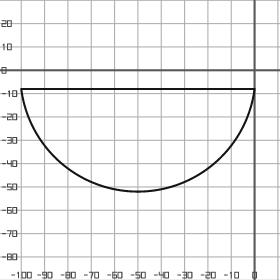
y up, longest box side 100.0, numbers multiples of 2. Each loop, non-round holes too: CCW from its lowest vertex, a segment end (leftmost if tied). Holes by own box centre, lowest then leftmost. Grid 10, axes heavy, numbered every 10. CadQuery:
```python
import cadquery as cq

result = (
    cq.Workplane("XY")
    .moveTo(-100.0, -8.0)
    .threePointArc((-50.0, -52.0), (0.0, -8.0))
    .close()
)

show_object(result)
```